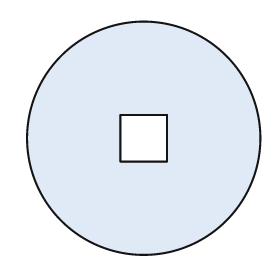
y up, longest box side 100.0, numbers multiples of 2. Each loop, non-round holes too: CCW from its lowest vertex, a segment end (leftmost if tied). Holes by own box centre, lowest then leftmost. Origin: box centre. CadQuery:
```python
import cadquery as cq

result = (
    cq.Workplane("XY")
    .moveTo(0.0, 0.0)
    .circle(50.0)
    .moveTo(-10.0, -10.0)
    .lineTo(10.0, -10.0)
    .lineTo(10.0, 10.0)
    .lineTo(-10.0, 10.0)
    .close()
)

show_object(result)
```